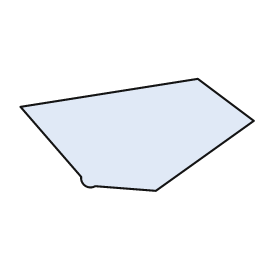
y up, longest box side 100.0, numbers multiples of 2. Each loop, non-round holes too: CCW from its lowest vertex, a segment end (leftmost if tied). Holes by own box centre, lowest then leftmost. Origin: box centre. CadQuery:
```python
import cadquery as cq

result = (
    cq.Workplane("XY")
    .moveTo(8.0, -24.0)
    .lineTo(50.0, 6.0)
    .lineTo(26.0, 24.0)
    .lineTo(-50.0, 12.0)
    .lineTo(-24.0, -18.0)
    .threePointArc((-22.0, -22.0), (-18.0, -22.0))
    .close()
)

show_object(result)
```